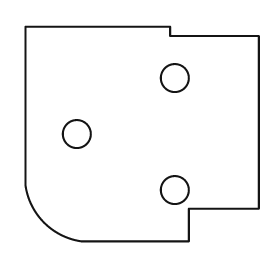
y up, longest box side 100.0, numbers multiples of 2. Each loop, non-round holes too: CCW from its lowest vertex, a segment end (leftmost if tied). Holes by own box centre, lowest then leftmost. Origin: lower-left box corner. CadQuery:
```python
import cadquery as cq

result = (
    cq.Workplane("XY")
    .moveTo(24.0, 0.0)
    .lineTo(70.0, 0.0)
    .lineTo(70.0, 14.0)
    .lineTo(100.0, 14.0)
    .lineTo(100.0, 88.0)
    .lineTo(62.0, 88.0)
    .lineTo(62.0, 92.0)
    .lineTo(0.0, 92.0)
    .lineTo(0.0, 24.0)
    .threePointArc((8.0, 8.0), (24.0, 0.0))
    .close()
    .moveTo(64.0, 22.0)
    .circle(6.0)
    .moveTo(22.0, 46.0)
    .circle(6.0)
    .moveTo(64.0, 70.0)
    .circle(6.0)
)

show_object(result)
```